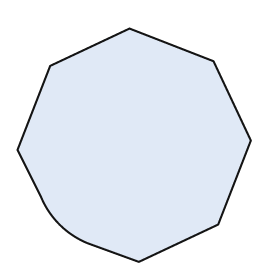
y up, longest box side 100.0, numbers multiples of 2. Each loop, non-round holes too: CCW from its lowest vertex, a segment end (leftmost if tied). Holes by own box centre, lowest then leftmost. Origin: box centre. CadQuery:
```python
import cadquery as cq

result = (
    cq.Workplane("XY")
    .moveTo(2.0, -50.0)
    .lineTo(36.0, -34.0)
    .lineTo(50.0, 2.0)
    .lineTo(34.0, 36.0)
    .lineTo(-2.0, 50.0)
    .lineTo(-36.0, 34.0)
    .lineTo(-50.0, -2.0)
    .lineTo(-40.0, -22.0)
    .threePointArc((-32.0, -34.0), (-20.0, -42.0))
    .close()
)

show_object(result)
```